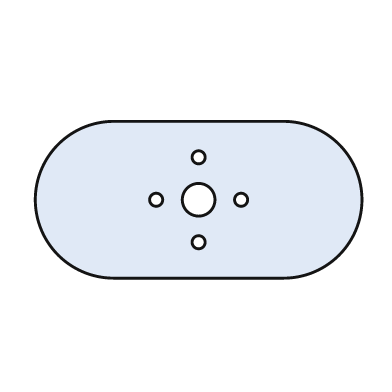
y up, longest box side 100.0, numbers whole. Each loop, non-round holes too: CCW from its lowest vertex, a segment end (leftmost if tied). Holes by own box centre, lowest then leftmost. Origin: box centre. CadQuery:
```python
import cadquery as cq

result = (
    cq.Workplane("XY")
    .moveTo(-26.0, -24.0)
    .lineTo(26.0, -24.0)
    .threePointArc((50.0, 0.0), (26.0, 24.0))
    .lineTo(-26.0, 24.0)
    .threePointArc((-50.0, 0.0), (-26.0, -24.0))
    .close()
    .moveTo(0.0, -13.0)
    .circle(2.0)
    .moveTo(-13.0, 0.0)
    .circle(2.0)
    .moveTo(0.0, 0.0)
    .circle(5.0)
    .moveTo(13.0, 0.0)
    .circle(2.0)
    .moveTo(0.0, 13.0)
    .circle(2.0)
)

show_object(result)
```